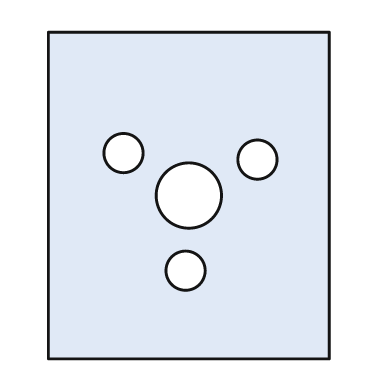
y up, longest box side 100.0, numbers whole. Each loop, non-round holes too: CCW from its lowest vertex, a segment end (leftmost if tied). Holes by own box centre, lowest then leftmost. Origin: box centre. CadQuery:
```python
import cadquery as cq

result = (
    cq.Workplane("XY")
    .moveTo(-43.0, -50.0)
    .lineTo(43.0, -50.0)
    .lineTo(43.0, 50.0)
    .lineTo(-43.0, 50.0)
    .close()
    .moveTo(-1.0, -23.0)
    .circle(6.0)
    .moveTo(0.0, 0.0)
    .circle(10.0)
    .moveTo(21.0, 11.0)
    .circle(6.0)
    .moveTo(-20.0, 13.0)
    .circle(6.0)
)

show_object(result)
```